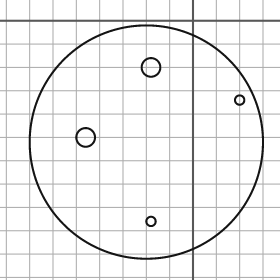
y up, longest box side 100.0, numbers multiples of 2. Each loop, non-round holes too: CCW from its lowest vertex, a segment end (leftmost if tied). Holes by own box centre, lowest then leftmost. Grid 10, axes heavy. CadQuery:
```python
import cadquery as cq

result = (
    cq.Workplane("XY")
    .moveTo(-20.0, -52.0)
    .circle(50.0)
    .moveTo(-18.0, -86.0)
    .circle(2.0)
    .moveTo(-46.0, -50.0)
    .circle(4.0)
    .moveTo(20.0, -34.0)
    .circle(2.0)
    .moveTo(-18.0, -20.0)
    .circle(4.0)
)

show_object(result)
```